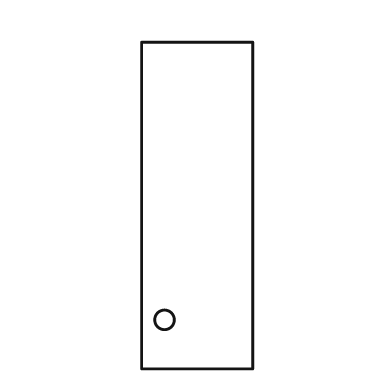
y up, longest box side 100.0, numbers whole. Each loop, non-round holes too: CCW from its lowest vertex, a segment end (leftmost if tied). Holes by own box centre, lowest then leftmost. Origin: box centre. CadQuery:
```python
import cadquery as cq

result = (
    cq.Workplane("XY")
    .moveTo(-17.0, -50.0)
    .lineTo(17.0, -50.0)
    .lineTo(17.0, 50.0)
    .lineTo(-17.0, 50.0)
    .close()
    .moveTo(-10.0, -35.0)
    .circle(3.0)
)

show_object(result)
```